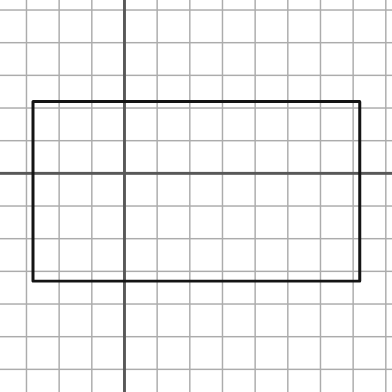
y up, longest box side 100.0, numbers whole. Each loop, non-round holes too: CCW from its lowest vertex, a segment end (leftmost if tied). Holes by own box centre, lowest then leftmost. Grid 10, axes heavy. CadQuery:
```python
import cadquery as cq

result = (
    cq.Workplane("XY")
    .moveTo(-28.0, -33.0)
    .lineTo(72.0, -33.0)
    .lineTo(72.0, 22.0)
    .lineTo(-28.0, 22.0)
    .close()
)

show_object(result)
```